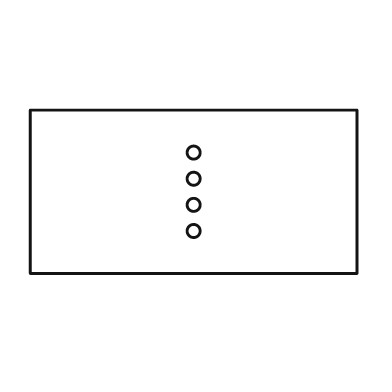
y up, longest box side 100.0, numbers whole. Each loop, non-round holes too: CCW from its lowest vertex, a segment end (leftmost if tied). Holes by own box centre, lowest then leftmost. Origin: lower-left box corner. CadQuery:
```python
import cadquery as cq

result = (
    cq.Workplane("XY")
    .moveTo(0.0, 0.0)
    .lineTo(100.0, 0.0)
    .lineTo(100.0, 50.0)
    .lineTo(0.0, 50.0)
    .close()
    .moveTo(50.0, 13.0)
    .circle(2.0)
    .moveTo(50.0, 21.0)
    .circle(2.0)
    .moveTo(50.0, 29.0)
    .circle(2.0)
    .moveTo(50.0, 37.0)
    .circle(2.0)
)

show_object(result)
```